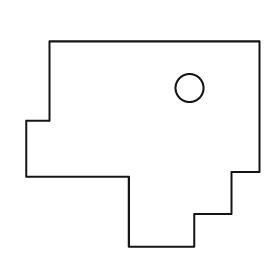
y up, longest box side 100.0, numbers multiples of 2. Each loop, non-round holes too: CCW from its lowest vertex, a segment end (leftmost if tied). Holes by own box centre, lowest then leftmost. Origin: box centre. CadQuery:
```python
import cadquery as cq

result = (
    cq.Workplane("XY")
    .moveTo(-6.0, -44.0)
    .lineTo(22.0, -44.0)
    .lineTo(22.0, -30.0)
    .lineTo(38.0, -30.0)
    .lineTo(38.0, -12.0)
    .lineTo(50.0, -12.0)
    .lineTo(50.0, 44.0)
    .lineTo(-40.0, 44.0)
    .lineTo(-40.0, 10.0)
    .lineTo(-50.0, 10.0)
    .lineTo(-50.0, -14.0)
    .lineTo(-6.0, -14.0)
    .close()
    .moveTo(20.0, 24.0)
    .circle(6.0)
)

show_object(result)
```